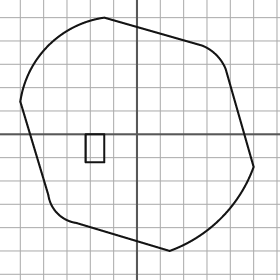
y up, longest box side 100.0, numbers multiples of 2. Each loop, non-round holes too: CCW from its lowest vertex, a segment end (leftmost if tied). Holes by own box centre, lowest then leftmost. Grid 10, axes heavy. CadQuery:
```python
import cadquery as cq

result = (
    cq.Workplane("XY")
    .moveTo(14.0, -50.0)
    .threePointArc((36.0, -36.0), (50.0, -14.0))
    .lineTo(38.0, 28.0)
    .threePointArc((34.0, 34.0), (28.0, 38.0))
    .lineTo(-14.0, 50.0)
    .threePointArc((-38.0, 38.0), (-50.0, 14.0))
    .lineTo(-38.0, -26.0)
    .threePointArc((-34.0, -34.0), (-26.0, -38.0))
    .close()
    .moveTo(-22.0, -12.0)
    .lineTo(-14.0, -12.0)
    .lineTo(-14.0, 0.0)
    .lineTo(-22.0, 0.0)
    .close()
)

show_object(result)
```